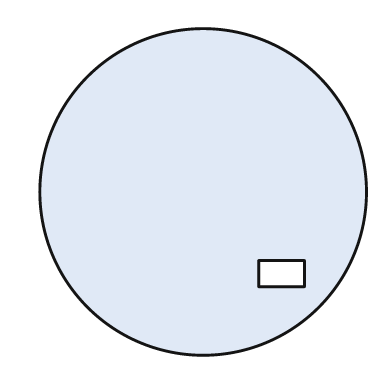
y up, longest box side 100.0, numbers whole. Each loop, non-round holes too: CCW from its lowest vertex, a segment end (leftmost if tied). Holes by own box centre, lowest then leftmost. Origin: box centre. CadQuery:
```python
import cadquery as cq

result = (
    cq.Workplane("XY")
    .moveTo(0.0, 0.0)
    .circle(50.0)
    .moveTo(17.0, -29.0)
    .lineTo(31.0, -29.0)
    .lineTo(31.0, -21.0)
    .lineTo(17.0, -21.0)
    .close()
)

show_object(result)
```